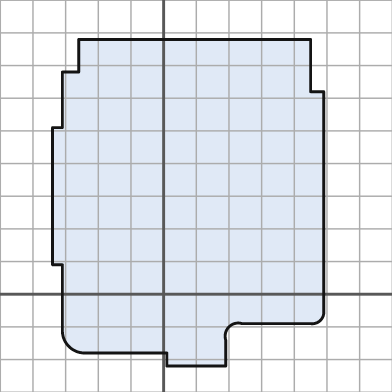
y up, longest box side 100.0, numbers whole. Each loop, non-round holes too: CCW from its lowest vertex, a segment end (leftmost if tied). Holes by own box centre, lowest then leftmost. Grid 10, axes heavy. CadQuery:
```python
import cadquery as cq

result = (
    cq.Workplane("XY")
    .moveTo(1.0, -22.0)
    .lineTo(19.0, -22.0)
    .lineTo(19.0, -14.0)
    .threePointArc((20.0, -10.0), (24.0, -9.0))
    .lineTo(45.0, -9.0)
    .threePointArc((48.0, -8.0), (49.0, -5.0))
    .lineTo(49.0, 62.0)
    .lineTo(45.0, 62.0)
    .lineTo(45.0, 78.0)
    .lineTo(-26.0, 78.0)
    .lineTo(-26.0, 68.0)
    .lineTo(-31.0, 68.0)
    .lineTo(-31.0, 51.0)
    .lineTo(-34.0, 51.0)
    .lineTo(-34.0, 9.0)
    .lineTo(-31.0, 9.0)
    .lineTo(-31.0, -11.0)
    .threePointArc((-29.0, -16.0), (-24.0, -18.0))
    .lineTo(1.0, -18.0)
    .close()
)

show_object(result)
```